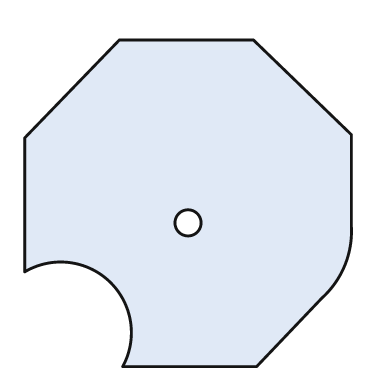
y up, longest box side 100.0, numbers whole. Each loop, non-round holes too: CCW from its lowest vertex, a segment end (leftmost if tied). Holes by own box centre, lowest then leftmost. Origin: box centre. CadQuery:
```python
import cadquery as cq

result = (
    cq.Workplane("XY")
    .moveTo(-20.0, -50.0)
    .lineTo(21.0, -50.0)
    .lineTo(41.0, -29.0)
    .threePointArc((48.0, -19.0), (50.0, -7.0))
    .lineTo(50.0, 21.0)
    .lineTo(20.0, 50.0)
    .lineTo(-21.0, 50.0)
    .lineTo(-50.0, 20.0)
    .lineTo(-50.0, -21.0)
    .threePointArc((-24.0, -24.0), (-20.0, -50.0))
    .close()
    .moveTo(0.0, -6.0)
    .circle(4.0)
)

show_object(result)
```